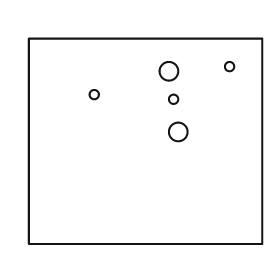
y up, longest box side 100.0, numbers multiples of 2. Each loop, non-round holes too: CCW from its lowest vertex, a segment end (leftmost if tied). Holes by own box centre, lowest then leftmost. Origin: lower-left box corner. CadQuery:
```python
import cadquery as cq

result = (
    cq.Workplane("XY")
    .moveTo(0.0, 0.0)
    .lineTo(100.0, 0.0)
    .lineTo(100.0, 88.0)
    .lineTo(0.0, 88.0)
    .close()
    .moveTo(64.0, 48.0)
    .circle(4.0)
    .moveTo(62.0, 62.0)
    .circle(2.0)
    .moveTo(28.0, 64.0)
    .circle(2.0)
    .moveTo(60.0, 74.0)
    .circle(4.0)
    .moveTo(86.0, 76.0)
    .circle(2.0)
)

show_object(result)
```